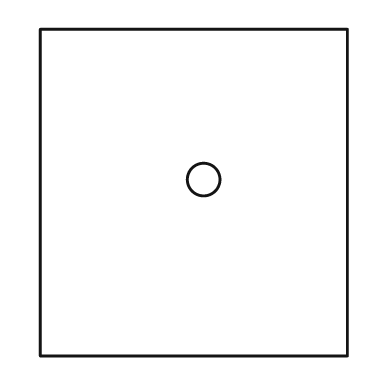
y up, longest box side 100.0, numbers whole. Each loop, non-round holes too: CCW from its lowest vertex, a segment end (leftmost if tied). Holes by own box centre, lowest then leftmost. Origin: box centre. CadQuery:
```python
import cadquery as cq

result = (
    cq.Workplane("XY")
    .moveTo(-47.0, -50.0)
    .lineTo(47.0, -50.0)
    .lineTo(47.0, 50.0)
    .lineTo(-47.0, 50.0)
    .close()
    .moveTo(3.0, 4.0)
    .circle(5.0)
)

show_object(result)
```